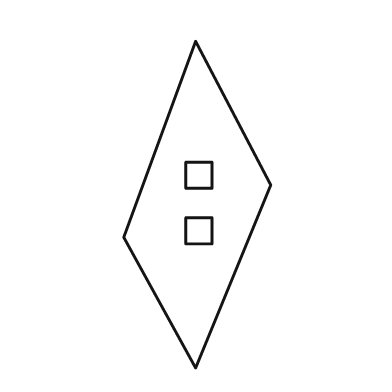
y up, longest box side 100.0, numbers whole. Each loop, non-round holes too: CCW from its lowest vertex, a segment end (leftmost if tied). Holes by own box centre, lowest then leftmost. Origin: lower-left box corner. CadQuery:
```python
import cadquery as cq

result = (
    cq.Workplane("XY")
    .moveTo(22.0, 0.0)
    .lineTo(45.0, 56.0)
    .lineTo(22.0, 100.0)
    .lineTo(0.0, 40.0)
    .close()
    .moveTo(19.0, 38.0)
    .lineTo(27.0, 38.0)
    .lineTo(27.0, 46.0)
    .lineTo(19.0, 46.0)
    .close()
    .moveTo(19.0, 55.0)
    .lineTo(27.0, 55.0)
    .lineTo(27.0, 63.0)
    .lineTo(19.0, 63.0)
    .close()
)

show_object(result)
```